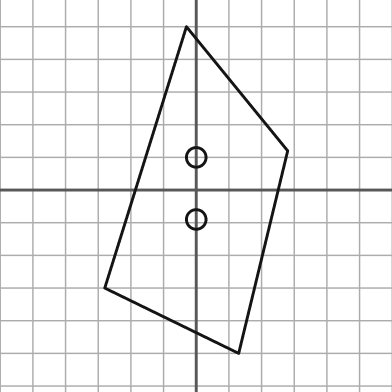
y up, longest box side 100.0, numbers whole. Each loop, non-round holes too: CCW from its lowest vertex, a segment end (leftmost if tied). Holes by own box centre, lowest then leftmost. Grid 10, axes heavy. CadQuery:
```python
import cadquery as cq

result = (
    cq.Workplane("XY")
    .moveTo(13.0, -50.0)
    .lineTo(28.0, 12.0)
    .lineTo(-3.0, 50.0)
    .lineTo(-28.0, -30.0)
    .close()
    .moveTo(0.0, -9.0)
    .circle(3.0)
    .moveTo(0.0, 10.0)
    .circle(3.0)
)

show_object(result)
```